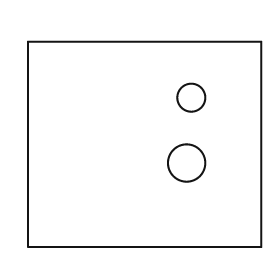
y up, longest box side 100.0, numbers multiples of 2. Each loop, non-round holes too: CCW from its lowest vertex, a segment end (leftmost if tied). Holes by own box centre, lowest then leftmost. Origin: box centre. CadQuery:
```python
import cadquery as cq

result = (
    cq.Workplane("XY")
    .moveTo(-50.0, -44.0)
    .lineTo(50.0, -44.0)
    .lineTo(50.0, 44.0)
    .lineTo(-50.0, 44.0)
    .close()
    .moveTo(18.0, -8.0)
    .circle(8.0)
    .moveTo(20.0, 20.0)
    .circle(6.0)
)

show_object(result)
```